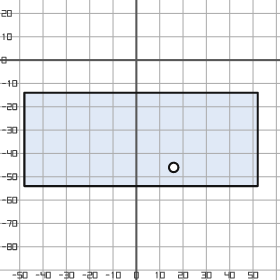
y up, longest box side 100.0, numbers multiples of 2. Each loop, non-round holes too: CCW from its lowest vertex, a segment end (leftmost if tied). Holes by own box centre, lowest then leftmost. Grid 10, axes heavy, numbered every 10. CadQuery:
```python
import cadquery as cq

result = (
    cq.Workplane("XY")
    .moveTo(-48.0, -54.0)
    .lineTo(52.0, -54.0)
    .lineTo(52.0, -14.0)
    .lineTo(-48.0, -14.0)
    .close()
    .moveTo(16.0, -46.0)
    .circle(2.0)
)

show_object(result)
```